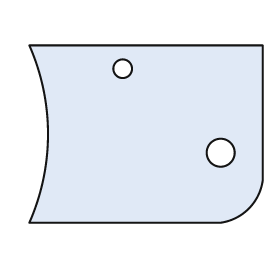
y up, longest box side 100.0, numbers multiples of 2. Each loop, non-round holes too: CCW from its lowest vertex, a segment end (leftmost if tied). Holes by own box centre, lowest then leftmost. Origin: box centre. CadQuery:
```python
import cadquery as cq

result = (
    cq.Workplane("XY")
    .moveTo(-50.0, -38.0)
    .lineTo(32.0, -38.0)
    .threePointArc((44.0, -32.0), (50.0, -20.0))
    .lineTo(50.0, 38.0)
    .lineTo(-50.0, 38.0)
    .threePointArc((-42.0, 0.0), (-50.0, -38.0))
    .close()
    .moveTo(32.0, -8.0)
    .circle(6.0)
    .moveTo(-10.0, 28.0)
    .circle(4.0)
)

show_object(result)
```